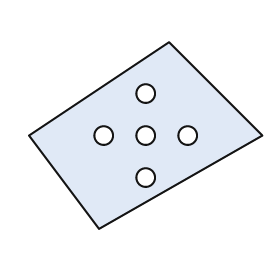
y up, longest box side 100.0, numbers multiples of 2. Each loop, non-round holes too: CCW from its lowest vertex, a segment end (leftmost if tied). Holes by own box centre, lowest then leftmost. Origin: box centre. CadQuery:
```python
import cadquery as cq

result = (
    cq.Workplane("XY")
    .moveTo(-20.0, -40.0)
    .lineTo(50.0, 0.0)
    .lineTo(10.0, 40.0)
    .lineTo(-50.0, 0.0)
    .close()
    .moveTo(0.0, -18.0)
    .circle(4.0)
    .moveTo(-18.0, 0.0)
    .circle(4.0)
    .moveTo(0.0, 0.0)
    .circle(4.0)
    .moveTo(18.0, 0.0)
    .circle(4.0)
    .moveTo(0.0, 18.0)
    .circle(4.0)
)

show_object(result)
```